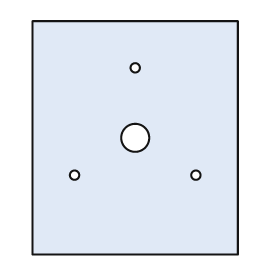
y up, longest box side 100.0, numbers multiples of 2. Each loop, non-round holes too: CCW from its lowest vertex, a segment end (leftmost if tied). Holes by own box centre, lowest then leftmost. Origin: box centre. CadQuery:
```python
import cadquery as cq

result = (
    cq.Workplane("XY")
    .moveTo(-44.0, -50.0)
    .lineTo(44.0, -50.0)
    .lineTo(44.0, 50.0)
    .lineTo(-44.0, 50.0)
    .close()
    .moveTo(-26.0, -16.0)
    .circle(2.0)
    .moveTo(26.0, -16.0)
    .circle(2.0)
    .moveTo(0.0, 0.0)
    .circle(6.0)
    .moveTo(0.0, 30.0)
    .circle(2.0)
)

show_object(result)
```